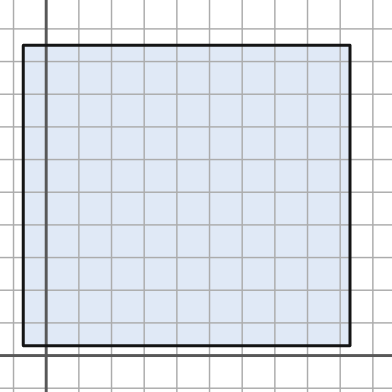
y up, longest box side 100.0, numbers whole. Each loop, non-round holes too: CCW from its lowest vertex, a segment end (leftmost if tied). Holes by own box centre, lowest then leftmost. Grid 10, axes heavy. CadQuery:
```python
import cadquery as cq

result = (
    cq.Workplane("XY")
    .moveTo(-7.0, 3.0)
    .lineTo(93.0, 3.0)
    .lineTo(93.0, 95.0)
    .lineTo(-7.0, 95.0)
    .close()
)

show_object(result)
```